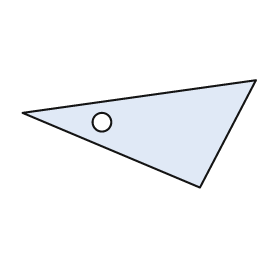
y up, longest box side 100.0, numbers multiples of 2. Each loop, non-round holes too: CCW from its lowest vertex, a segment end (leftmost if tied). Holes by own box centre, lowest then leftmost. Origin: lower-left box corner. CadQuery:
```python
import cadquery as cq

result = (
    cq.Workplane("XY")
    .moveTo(76.0, 0.0)
    .lineTo(100.0, 46.0)
    .lineTo(0.0, 32.0)
    .close()
    .moveTo(34.0, 28.0)
    .circle(4.0)
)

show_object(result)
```